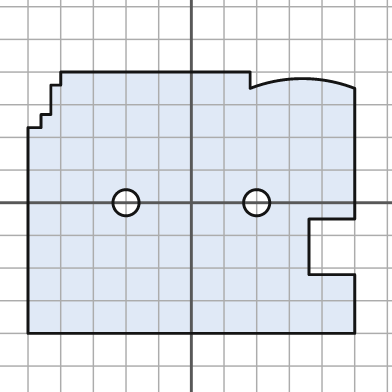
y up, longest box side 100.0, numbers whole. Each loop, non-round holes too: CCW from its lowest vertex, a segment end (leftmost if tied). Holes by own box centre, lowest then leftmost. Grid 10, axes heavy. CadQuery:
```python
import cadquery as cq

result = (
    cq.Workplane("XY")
    .moveTo(-50.0, -40.0)
    .lineTo(50.0, -40.0)
    .lineTo(50.0, -22.0)
    .lineTo(36.0, -22.0)
    .lineTo(36.0, -5.0)
    .lineTo(50.0, -5.0)
    .lineTo(50.0, 35.0)
    .threePointArc((34.0, 38.0), (18.0, 35.0))
    .lineTo(18.0, 40.0)
    .lineTo(-40.0, 40.0)
    .lineTo(-40.0, 36.0)
    .lineTo(-43.0, 36.0)
    .lineTo(-43.0, 27.0)
    .lineTo(-46.0, 27.0)
    .lineTo(-46.0, 23.0)
    .lineTo(-50.0, 23.0)
    .close()
    .moveTo(-20.0, 0.0)
    .circle(4.0)
    .moveTo(20.0, 0.0)
    .circle(4.0)
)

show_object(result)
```